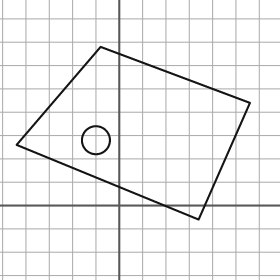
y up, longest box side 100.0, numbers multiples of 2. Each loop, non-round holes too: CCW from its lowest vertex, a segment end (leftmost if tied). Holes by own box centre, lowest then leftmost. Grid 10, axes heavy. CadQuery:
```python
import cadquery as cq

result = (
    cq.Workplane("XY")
    .moveTo(34.0, -6.0)
    .lineTo(56.0, 44.0)
    .lineTo(-8.0, 68.0)
    .lineTo(-44.0, 26.0)
    .close()
    .moveTo(-10.0, 28.0)
    .circle(6.0)
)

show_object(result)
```